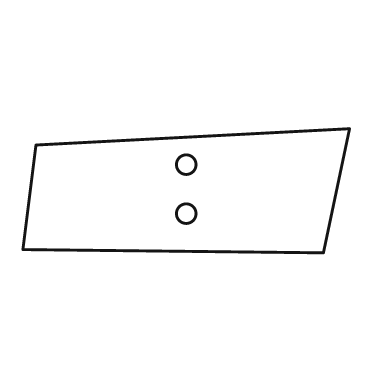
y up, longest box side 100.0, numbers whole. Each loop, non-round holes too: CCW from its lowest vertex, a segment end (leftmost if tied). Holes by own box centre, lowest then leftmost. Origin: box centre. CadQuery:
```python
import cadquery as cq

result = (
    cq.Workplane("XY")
    .moveTo(42.0, -19.0)
    .lineTo(50.0, 19.0)
    .lineTo(-46.0, 14.0)
    .lineTo(-50.0, -18.0)
    .close()
    .moveTo(0.0, -7.0)
    .circle(3.0)
    .moveTo(0.0, 8.0)
    .circle(3.0)
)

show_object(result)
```